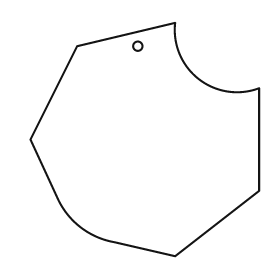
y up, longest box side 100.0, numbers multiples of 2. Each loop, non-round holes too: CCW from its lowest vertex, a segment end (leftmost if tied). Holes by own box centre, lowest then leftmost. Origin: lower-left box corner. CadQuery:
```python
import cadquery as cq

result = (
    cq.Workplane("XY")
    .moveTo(62.0, 0.0)
    .lineTo(98.0, 28.0)
    .lineTo(98.0, 72.0)
    .threePointArc((72.0, 76.0), (62.0, 100.0))
    .lineTo(20.0, 90.0)
    .lineTo(0.0, 50.0)
    .lineTo(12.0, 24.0)
    .threePointArc((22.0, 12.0), (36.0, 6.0))
    .close()
    .moveTo(46.0, 90.0)
    .circle(2.0)
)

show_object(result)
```